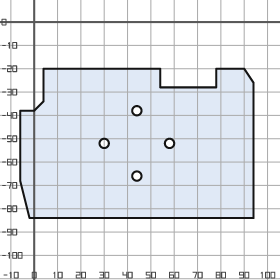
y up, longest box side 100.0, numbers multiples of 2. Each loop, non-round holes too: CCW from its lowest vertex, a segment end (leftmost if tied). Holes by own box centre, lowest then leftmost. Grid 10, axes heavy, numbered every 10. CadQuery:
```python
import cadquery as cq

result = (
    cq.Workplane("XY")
    .moveTo(-2.0, -84.0)
    .lineTo(94.0, -84.0)
    .lineTo(94.0, -26.0)
    .lineTo(90.0, -20.0)
    .lineTo(78.0, -20.0)
    .lineTo(78.0, -28.0)
    .lineTo(54.0, -28.0)
    .lineTo(54.0, -20.0)
    .lineTo(4.0, -20.0)
    .lineTo(4.0, -34.0)
    .lineTo(0.0, -38.0)
    .lineTo(-6.0, -38.0)
    .lineTo(-6.0, -68.0)
    .close()
    .moveTo(44.0, -66.0)
    .circle(2.0)
    .moveTo(30.0, -52.0)
    .circle(2.0)
    .moveTo(58.0, -52.0)
    .circle(2.0)
    .moveTo(44.0, -38.0)
    .circle(2.0)
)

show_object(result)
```